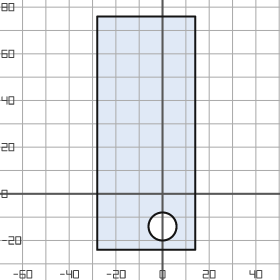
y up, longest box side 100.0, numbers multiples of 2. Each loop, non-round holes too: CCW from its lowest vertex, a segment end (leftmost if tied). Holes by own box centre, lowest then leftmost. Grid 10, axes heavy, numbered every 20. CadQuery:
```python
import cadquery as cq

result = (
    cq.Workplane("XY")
    .moveTo(-28.0, -24.0)
    .lineTo(14.0, -24.0)
    .lineTo(14.0, 76.0)
    .lineTo(-28.0, 76.0)
    .close()
    .moveTo(0.0, -14.0)
    .circle(6.0)
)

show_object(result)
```